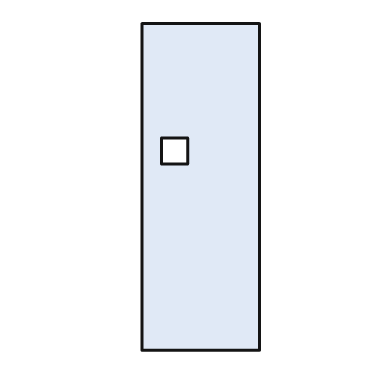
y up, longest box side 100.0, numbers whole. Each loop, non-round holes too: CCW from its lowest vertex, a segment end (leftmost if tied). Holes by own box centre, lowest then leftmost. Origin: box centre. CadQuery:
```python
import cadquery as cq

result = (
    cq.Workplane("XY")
    .moveTo(-18.0, -50.0)
    .lineTo(18.0, -50.0)
    .lineTo(18.0, 50.0)
    .lineTo(-18.0, 50.0)
    .close()
    .moveTo(-12.0, 7.0)
    .lineTo(-4.0, 7.0)
    .lineTo(-4.0, 15.0)
    .lineTo(-12.0, 15.0)
    .close()
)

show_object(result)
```